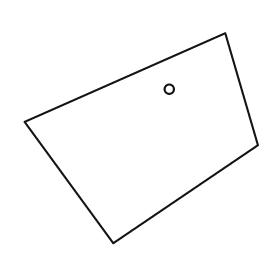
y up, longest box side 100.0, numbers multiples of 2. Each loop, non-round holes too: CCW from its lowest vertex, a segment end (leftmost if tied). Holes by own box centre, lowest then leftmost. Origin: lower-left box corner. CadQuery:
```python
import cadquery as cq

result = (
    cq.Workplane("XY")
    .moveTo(38.0, 0.0)
    .lineTo(100.0, 42.0)
    .lineTo(86.0, 90.0)
    .lineTo(0.0, 52.0)
    .close()
    .moveTo(62.0, 66.0)
    .circle(2.0)
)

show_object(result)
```